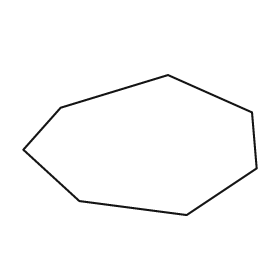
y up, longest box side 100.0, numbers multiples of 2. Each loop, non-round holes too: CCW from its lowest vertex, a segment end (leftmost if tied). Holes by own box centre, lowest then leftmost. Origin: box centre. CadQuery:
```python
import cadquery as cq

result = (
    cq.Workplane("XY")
    .moveTo(20.0, -30.0)
    .lineTo(50.0, -10.0)
    .lineTo(48.0, 14.0)
    .lineTo(12.0, 30.0)
    .lineTo(-34.0, 16.0)
    .lineTo(-50.0, -2.0)
    .lineTo(-26.0, -24.0)
    .close()
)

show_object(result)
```